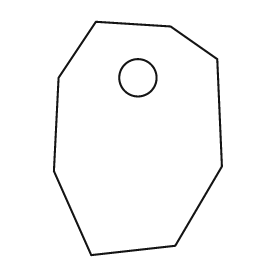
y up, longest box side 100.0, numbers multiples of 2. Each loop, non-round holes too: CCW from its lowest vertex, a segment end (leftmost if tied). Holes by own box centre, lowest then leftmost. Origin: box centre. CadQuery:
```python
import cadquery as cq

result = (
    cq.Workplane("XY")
    .moveTo(-20.0, -50.0)
    .lineTo(16.0, -46.0)
    .lineTo(36.0, -12.0)
    .lineTo(34.0, 34.0)
    .lineTo(14.0, 48.0)
    .lineTo(-18.0, 50.0)
    .lineTo(-34.0, 26.0)
    .lineTo(-36.0, -14.0)
    .close()
    .moveTo(0.0, 26.0)
    .circle(8.0)
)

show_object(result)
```